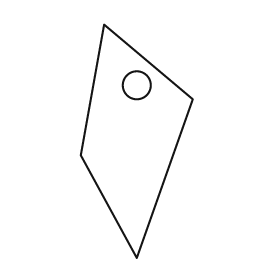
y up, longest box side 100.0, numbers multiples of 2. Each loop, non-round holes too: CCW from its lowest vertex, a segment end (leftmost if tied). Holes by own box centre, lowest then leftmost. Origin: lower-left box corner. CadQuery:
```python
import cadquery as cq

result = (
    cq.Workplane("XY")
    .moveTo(24.0, 0.0)
    .lineTo(48.0, 68.0)
    .lineTo(10.0, 100.0)
    .lineTo(0.0, 44.0)
    .close()
    .moveTo(24.0, 74.0)
    .circle(6.0)
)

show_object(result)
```